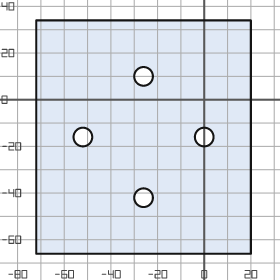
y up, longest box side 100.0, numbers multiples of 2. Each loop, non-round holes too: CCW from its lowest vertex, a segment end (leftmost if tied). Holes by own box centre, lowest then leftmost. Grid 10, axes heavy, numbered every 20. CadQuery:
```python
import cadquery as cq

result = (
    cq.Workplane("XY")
    .moveTo(-72.0, -66.0)
    .lineTo(20.0, -66.0)
    .lineTo(20.0, 34.0)
    .lineTo(-72.0, 34.0)
    .close()
    .moveTo(-26.0, -42.0)
    .circle(4.0)
    .moveTo(-52.0, -16.0)
    .circle(4.0)
    .moveTo(0.0, -16.0)
    .circle(4.0)
    .moveTo(-26.0, 10.0)
    .circle(4.0)
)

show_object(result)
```